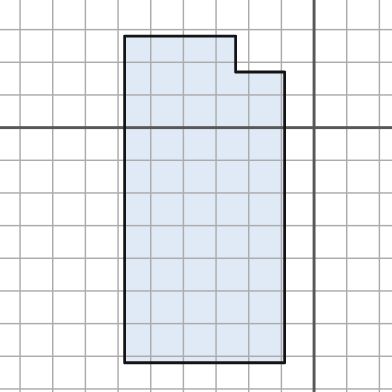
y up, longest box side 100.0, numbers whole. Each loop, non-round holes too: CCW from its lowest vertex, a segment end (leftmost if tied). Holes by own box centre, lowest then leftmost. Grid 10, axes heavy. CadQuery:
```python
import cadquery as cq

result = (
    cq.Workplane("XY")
    .moveTo(-58.0, -72.0)
    .lineTo(-9.0, -72.0)
    .lineTo(-9.0, 17.0)
    .lineTo(-24.0, 17.0)
    .lineTo(-24.0, 28.0)
    .lineTo(-58.0, 28.0)
    .close()
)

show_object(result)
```